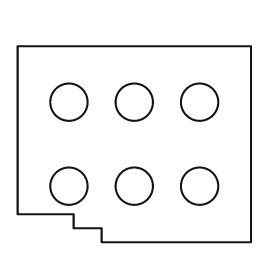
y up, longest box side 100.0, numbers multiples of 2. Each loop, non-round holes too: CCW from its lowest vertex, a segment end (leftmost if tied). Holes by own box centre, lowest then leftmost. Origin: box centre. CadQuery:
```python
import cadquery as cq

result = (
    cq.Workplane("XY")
    .moveTo(-14.0, -42.0)
    .lineTo(50.0, -42.0)
    .lineTo(50.0, 42.0)
    .lineTo(-50.0, 42.0)
    .lineTo(-50.0, -30.0)
    .lineTo(-26.0, -30.0)
    .lineTo(-26.0, -36.0)
    .lineTo(-14.0, -36.0)
    .close()
    .moveTo(-28.0, -18.0)
    .circle(8.0)
    .moveTo(0.0, -18.0)
    .circle(8.0)
    .moveTo(28.0, -18.0)
    .circle(8.0)
    .moveTo(-28.0, 18.0)
    .circle(8.0)
    .moveTo(0.0, 18.0)
    .circle(8.0)
    .moveTo(28.0, 18.0)
    .circle(8.0)
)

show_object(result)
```